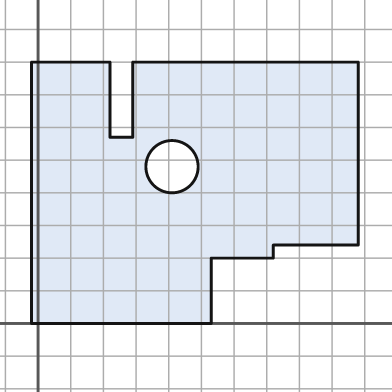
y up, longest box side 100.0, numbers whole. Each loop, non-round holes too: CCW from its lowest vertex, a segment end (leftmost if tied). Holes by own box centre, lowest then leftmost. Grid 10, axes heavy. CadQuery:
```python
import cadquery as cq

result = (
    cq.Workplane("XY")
    .moveTo(-2.0, 0.0)
    .lineTo(53.0, 0.0)
    .lineTo(53.0, 20.0)
    .lineTo(72.0, 20.0)
    .lineTo(72.0, 24.0)
    .lineTo(98.0, 24.0)
    .lineTo(98.0, 80.0)
    .lineTo(29.0, 80.0)
    .lineTo(29.0, 57.0)
    .lineTo(22.0, 57.0)
    .lineTo(22.0, 80.0)
    .lineTo(-2.0, 80.0)
    .close()
    .moveTo(41.0, 48.0)
    .circle(8.0)
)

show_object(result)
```